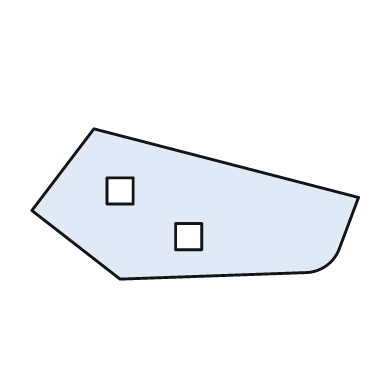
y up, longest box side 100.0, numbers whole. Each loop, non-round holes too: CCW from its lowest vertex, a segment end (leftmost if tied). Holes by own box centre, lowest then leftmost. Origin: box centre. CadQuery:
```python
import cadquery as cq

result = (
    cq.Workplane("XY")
    .moveTo(-23.0, -23.0)
    .lineTo(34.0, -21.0)
    .threePointArc((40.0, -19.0), (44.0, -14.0))
    .lineTo(50.0, 2.0)
    .lineTo(-31.0, 23.0)
    .lineTo(-50.0, -2.0)
    .close()
    .moveTo(-6.0, -14.0)
    .lineTo(2.0, -14.0)
    .lineTo(2.0, -6.0)
    .lineTo(-6.0, -6.0)
    .close()
    .moveTo(-27.0, 0.0)
    .lineTo(-19.0, 0.0)
    .lineTo(-19.0, 8.0)
    .lineTo(-27.0, 8.0)
    .close()
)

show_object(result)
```